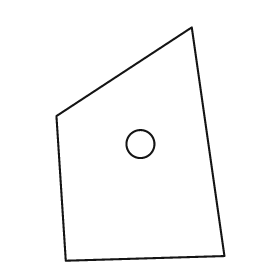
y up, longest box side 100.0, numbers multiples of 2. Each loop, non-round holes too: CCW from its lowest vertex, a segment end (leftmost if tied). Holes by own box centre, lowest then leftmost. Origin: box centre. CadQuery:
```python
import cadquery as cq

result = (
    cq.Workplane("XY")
    .moveTo(-32.0, -50.0)
    .lineTo(36.0, -48.0)
    .lineTo(22.0, 50.0)
    .lineTo(-36.0, 12.0)
    .close()
    .moveTo(0.0, 0.0)
    .circle(6.0)
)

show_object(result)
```